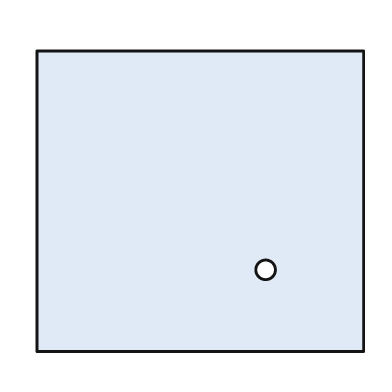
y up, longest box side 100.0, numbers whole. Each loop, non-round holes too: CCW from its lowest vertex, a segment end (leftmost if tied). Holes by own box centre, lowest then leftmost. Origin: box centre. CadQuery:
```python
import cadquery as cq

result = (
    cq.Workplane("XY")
    .moveTo(-50.0, -46.0)
    .lineTo(50.0, -46.0)
    .lineTo(50.0, 46.0)
    .lineTo(-50.0, 46.0)
    .close()
    .moveTo(20.0, -21.0)
    .circle(3.0)
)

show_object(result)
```